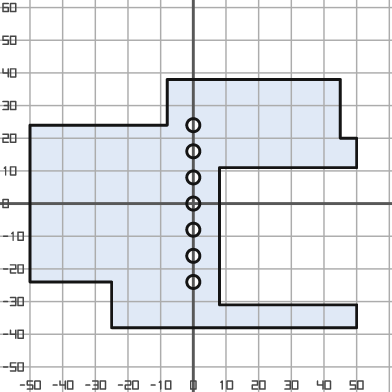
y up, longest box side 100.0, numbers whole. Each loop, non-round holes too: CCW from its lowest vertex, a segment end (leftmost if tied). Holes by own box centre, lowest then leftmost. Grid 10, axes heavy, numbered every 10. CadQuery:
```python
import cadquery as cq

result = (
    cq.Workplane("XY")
    .moveTo(-25.0, -38.0)
    .lineTo(50.0, -38.0)
    .lineTo(50.0, -31.0)
    .lineTo(8.0, -31.0)
    .lineTo(8.0, 11.0)
    .lineTo(50.0, 11.0)
    .lineTo(50.0, 20.0)
    .lineTo(45.0, 20.0)
    .lineTo(45.0, 38.0)
    .lineTo(-8.0, 38.0)
    .lineTo(-8.0, 24.0)
    .lineTo(-50.0, 24.0)
    .lineTo(-50.0, -24.0)
    .lineTo(-25.0, -24.0)
    .close()
    .moveTo(0.0, -24.0)
    .circle(2.0)
    .moveTo(0.0, -16.0)
    .circle(2.0)
    .moveTo(0.0, -8.0)
    .circle(2.0)
    .moveTo(0.0, 0.0)
    .circle(2.0)
    .moveTo(0.0, 8.0)
    .circle(2.0)
    .moveTo(0.0, 16.0)
    .circle(2.0)
    .moveTo(0.0, 24.0)
    .circle(2.0)
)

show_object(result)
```